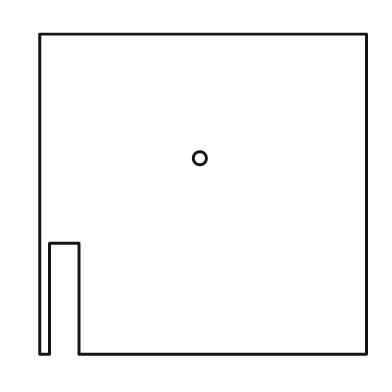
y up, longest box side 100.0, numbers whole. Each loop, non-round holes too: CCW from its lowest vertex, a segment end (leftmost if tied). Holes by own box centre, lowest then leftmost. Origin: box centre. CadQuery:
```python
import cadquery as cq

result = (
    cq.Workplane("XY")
    .moveTo(-50.0, -49.0)
    .lineTo(-47.0, -49.0)
    .lineTo(-47.0, -15.0)
    .lineTo(-38.0, -15.0)
    .lineTo(-38.0, -49.0)
    .lineTo(50.0, -49.0)
    .lineTo(50.0, 49.0)
    .lineTo(-50.0, 49.0)
    .close()
    .moveTo(-1.0, 11.0)
    .circle(2.0)
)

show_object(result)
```